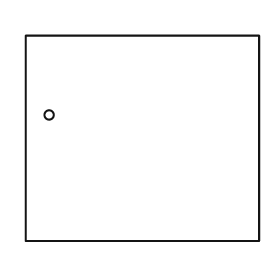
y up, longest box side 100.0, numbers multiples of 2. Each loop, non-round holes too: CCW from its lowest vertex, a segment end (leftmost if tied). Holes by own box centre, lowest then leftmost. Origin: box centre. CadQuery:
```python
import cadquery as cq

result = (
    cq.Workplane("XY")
    .moveTo(-50.0, -44.0)
    .lineTo(50.0, -44.0)
    .lineTo(50.0, 44.0)
    .lineTo(-50.0, 44.0)
    .close()
    .moveTo(-40.0, 10.0)
    .circle(2.0)
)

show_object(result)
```